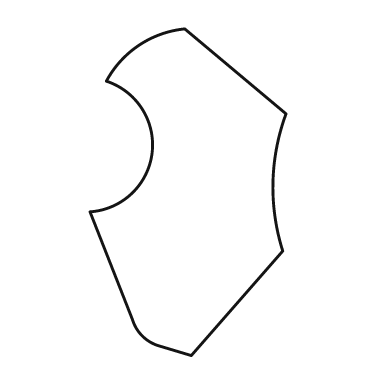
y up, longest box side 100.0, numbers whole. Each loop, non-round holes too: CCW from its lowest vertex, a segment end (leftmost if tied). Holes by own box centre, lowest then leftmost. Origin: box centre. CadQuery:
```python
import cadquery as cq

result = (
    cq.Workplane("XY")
    .moveTo(1.0, -50.0)
    .lineTo(29.0, -18.0)
    .threePointArc((26.0, 3.0), (30.0, 24.0))
    .lineTo(-1.0, 50.0)
    .threePointArc((-15.0, 45.0), (-25.0, 34.0))
    .threePointArc((-11.0, 12.0), (-30.0, -6.0))
    .lineTo(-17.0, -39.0)
    .threePointArc((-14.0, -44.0), (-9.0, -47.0))
    .close()
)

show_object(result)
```